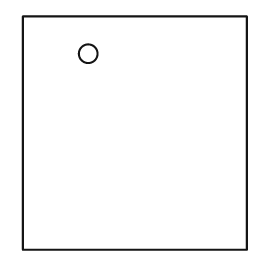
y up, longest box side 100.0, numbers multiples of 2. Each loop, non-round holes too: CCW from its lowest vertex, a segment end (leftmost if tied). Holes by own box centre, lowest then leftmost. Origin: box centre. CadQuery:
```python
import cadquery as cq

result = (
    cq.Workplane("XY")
    .moveTo(-48.0, -50.0)
    .lineTo(48.0, -50.0)
    .lineTo(48.0, 50.0)
    .lineTo(-48.0, 50.0)
    .close()
    .moveTo(-20.0, 34.0)
    .circle(4.0)
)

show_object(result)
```